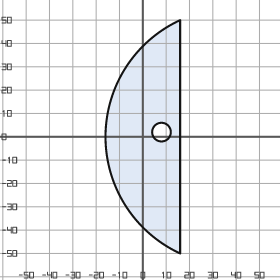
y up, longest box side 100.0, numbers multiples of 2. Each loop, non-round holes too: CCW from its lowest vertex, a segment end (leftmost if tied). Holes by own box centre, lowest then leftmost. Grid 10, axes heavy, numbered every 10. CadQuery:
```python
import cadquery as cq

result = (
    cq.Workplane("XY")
    .moveTo(16.0, -50.0)
    .lineTo(16.0, 50.0)
    .threePointArc((-16.0, 0.0), (16.0, -50.0))
    .close()
    .moveTo(8.0, 2.0)
    .circle(4.0)
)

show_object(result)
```